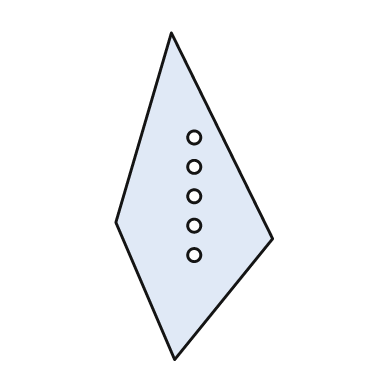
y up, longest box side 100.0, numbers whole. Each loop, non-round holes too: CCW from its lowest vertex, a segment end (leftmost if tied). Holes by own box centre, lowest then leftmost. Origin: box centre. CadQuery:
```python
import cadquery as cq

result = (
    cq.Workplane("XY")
    .moveTo(-6.0, -50.0)
    .lineTo(24.0, -13.0)
    .lineTo(-7.0, 50.0)
    .lineTo(-24.0, -8.0)
    .close()
    .moveTo(0.0, -18.0)
    .circle(2.0)
    .moveTo(0.0, -9.0)
    .circle(2.0)
    .moveTo(0.0, 0.0)
    .circle(2.0)
    .moveTo(0.0, 9.0)
    .circle(2.0)
    .moveTo(0.0, 18.0)
    .circle(2.0)
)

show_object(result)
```